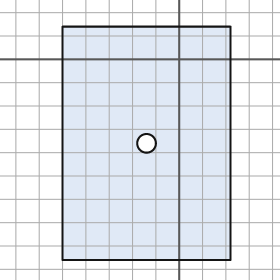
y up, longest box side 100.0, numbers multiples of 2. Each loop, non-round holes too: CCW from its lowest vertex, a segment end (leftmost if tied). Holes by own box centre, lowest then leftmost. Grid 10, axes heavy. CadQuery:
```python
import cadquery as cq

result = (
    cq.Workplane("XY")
    .moveTo(-50.0, -86.0)
    .lineTo(22.0, -86.0)
    .lineTo(22.0, 14.0)
    .lineTo(-50.0, 14.0)
    .close()
    .moveTo(-14.0, -36.0)
    .circle(4.0)
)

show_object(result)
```